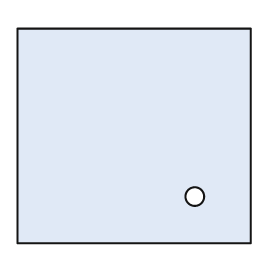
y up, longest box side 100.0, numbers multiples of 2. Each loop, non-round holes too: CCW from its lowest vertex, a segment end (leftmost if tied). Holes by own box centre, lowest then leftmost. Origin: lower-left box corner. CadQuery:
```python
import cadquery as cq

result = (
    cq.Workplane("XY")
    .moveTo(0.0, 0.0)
    .lineTo(100.0, 0.0)
    .lineTo(100.0, 92.0)
    .lineTo(0.0, 92.0)
    .close()
    .moveTo(76.0, 20.0)
    .circle(4.0)
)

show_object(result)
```